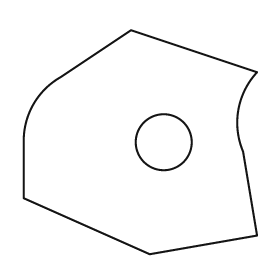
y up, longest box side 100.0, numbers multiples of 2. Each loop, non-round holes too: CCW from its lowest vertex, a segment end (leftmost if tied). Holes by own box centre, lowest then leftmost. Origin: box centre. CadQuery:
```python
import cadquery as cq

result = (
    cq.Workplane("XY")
    .moveTo(4.0, -48.0)
    .lineTo(50.0, -40.0)
    .lineTo(44.0, -4.0)
    .threePointArc((42.0, 14.0), (50.0, 30.0))
    .lineTo(-4.0, 48.0)
    .lineTo(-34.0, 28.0)
    .threePointArc((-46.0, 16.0), (-50.0, 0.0))
    .lineTo(-50.0, -24.0)
    .close()
    .moveTo(10.0, 0.0)
    .circle(12.0)
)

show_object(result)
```